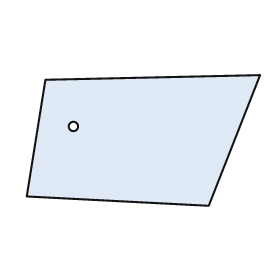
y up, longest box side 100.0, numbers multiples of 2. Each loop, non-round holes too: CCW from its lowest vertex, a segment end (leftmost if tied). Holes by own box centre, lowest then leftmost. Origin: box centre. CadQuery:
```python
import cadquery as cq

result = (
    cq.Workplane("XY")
    .moveTo(28.0, -28.0)
    .lineTo(50.0, 28.0)
    .lineTo(-42.0, 26.0)
    .lineTo(-50.0, -24.0)
    .close()
    .moveTo(-30.0, 6.0)
    .circle(2.0)
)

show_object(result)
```